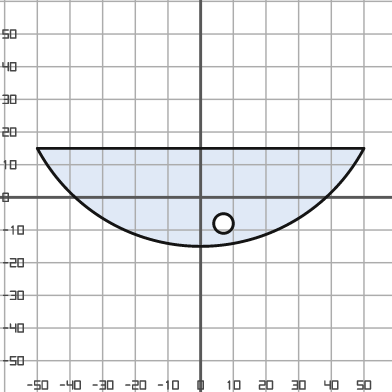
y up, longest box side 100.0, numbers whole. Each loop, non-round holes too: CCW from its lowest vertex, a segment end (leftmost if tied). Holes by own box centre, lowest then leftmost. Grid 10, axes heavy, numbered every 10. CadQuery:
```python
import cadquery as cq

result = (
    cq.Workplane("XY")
    .moveTo(-50.0, 15.0)
    .threePointArc((0.0, -15.0), (50.0, 15.0))
    .close()
    .moveTo(7.0, -8.0)
    .circle(3.0)
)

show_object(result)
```